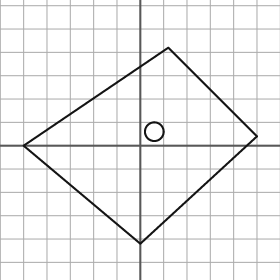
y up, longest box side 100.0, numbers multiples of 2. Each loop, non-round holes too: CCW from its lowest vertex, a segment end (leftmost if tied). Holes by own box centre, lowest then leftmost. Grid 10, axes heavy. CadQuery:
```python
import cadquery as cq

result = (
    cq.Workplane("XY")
    .moveTo(0.0, -42.0)
    .lineTo(50.0, 4.0)
    .lineTo(12.0, 42.0)
    .lineTo(-50.0, 0.0)
    .close()
    .moveTo(6.0, 6.0)
    .circle(4.0)
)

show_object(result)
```